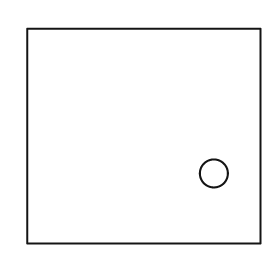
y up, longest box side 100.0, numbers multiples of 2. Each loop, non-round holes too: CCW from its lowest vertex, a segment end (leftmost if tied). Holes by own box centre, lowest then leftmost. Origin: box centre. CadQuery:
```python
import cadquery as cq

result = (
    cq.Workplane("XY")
    .moveTo(-50.0, -46.0)
    .lineTo(50.0, -46.0)
    .lineTo(50.0, 46.0)
    .lineTo(-50.0, 46.0)
    .close()
    .moveTo(30.0, -16.0)
    .circle(6.0)
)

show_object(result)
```